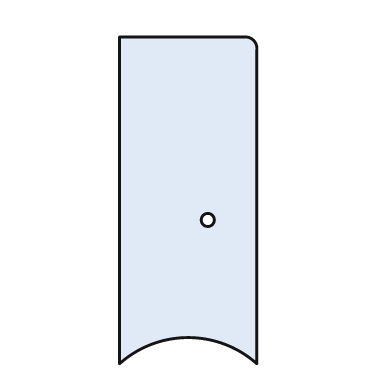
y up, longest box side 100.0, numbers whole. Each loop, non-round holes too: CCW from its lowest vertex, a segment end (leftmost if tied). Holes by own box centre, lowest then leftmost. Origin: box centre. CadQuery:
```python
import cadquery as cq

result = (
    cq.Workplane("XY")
    .moveTo(-21.0, -50.0)
    .threePointArc((0.0, -42.0), (21.0, -50.0))
    .lineTo(21.0, 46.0)
    .threePointArc((20.0, 49.0), (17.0, 50.0))
    .lineTo(-21.0, 50.0)
    .close()
    .moveTo(6.0, -6.0)
    .circle(2.0)
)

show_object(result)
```